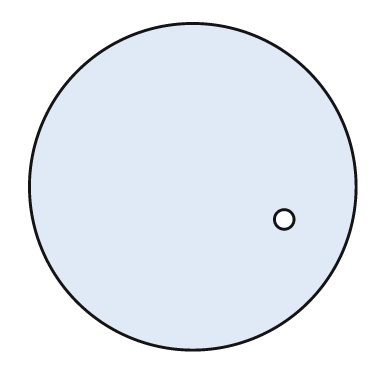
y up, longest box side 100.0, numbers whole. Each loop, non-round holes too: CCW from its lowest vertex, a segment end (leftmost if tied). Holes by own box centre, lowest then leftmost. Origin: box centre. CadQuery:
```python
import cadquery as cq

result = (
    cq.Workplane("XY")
    .moveTo(0.0, 0.0)
    .circle(50.0)
    .moveTo(28.0, -10.0)
    .circle(3.0)
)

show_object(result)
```